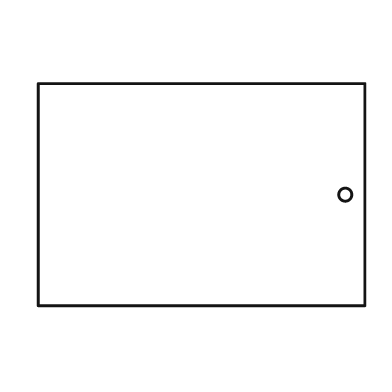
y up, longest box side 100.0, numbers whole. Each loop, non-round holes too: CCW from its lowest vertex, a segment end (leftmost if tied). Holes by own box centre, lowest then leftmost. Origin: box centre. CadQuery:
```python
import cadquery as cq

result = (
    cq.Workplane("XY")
    .moveTo(-50.0, -34.0)
    .lineTo(50.0, -34.0)
    .lineTo(50.0, 34.0)
    .lineTo(-50.0, 34.0)
    .close()
    .moveTo(44.0, 0.0)
    .circle(2.0)
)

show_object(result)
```